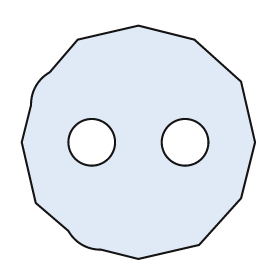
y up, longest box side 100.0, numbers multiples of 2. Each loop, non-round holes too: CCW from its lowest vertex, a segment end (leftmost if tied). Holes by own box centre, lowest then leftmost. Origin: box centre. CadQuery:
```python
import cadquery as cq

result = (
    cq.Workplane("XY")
    .moveTo(0.0, -50.0)
    .lineTo(26.0, -44.0)
    .lineTo(44.0, -24.0)
    .lineTo(50.0, 0.0)
    .lineTo(44.0, 26.0)
    .lineTo(24.0, 44.0)
    .lineTo(0.0, 50.0)
    .lineTo(-26.0, 44.0)
    .lineTo(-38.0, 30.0)
    .threePointArc((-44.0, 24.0), (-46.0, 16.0))
    .lineTo(-50.0, 0.0)
    .lineTo(-44.0, -26.0)
    .lineTo(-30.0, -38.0)
    .threePointArc((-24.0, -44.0), (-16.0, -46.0))
    .close()
    .moveTo(-20.0, 0.0)
    .circle(10.0)
    .moveTo(20.0, 0.0)
    .circle(10.0)
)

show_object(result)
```